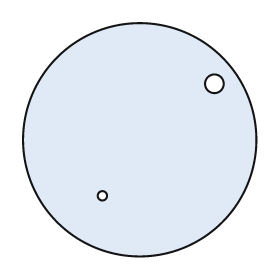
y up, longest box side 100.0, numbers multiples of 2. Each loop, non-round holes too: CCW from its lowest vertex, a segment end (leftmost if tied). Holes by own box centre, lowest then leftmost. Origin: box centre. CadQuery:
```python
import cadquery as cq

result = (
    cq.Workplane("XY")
    .moveTo(0.0, 0.0)
    .circle(50.0)
    .moveTo(-16.0, -24.0)
    .circle(2.0)
    .moveTo(32.0, 24.0)
    .circle(4.0)
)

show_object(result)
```